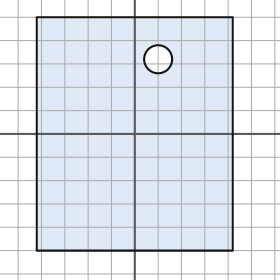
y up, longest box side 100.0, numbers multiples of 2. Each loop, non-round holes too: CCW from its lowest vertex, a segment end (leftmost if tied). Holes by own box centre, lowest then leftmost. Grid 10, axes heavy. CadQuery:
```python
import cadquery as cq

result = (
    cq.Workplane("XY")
    .moveTo(-42.0, -50.0)
    .lineTo(42.0, -50.0)
    .lineTo(42.0, 50.0)
    .lineTo(-42.0, 50.0)
    .close()
    .moveTo(10.0, 32.0)
    .circle(6.0)
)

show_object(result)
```